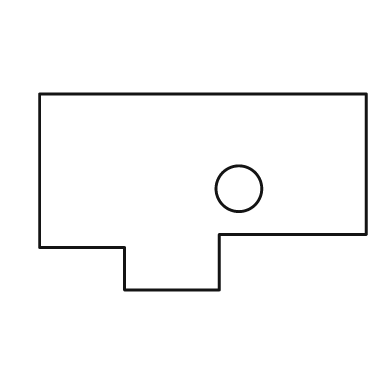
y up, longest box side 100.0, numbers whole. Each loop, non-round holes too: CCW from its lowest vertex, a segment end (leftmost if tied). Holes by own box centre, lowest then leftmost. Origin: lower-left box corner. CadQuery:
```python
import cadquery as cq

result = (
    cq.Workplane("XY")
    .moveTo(26.0, 0.0)
    .lineTo(55.0, 0.0)
    .lineTo(55.0, 17.0)
    .lineTo(100.0, 17.0)
    .lineTo(100.0, 60.0)
    .lineTo(0.0, 60.0)
    .lineTo(0.0, 13.0)
    .lineTo(26.0, 13.0)
    .close()
    .moveTo(61.0, 31.0)
    .circle(7.0)
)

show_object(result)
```